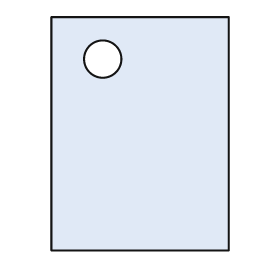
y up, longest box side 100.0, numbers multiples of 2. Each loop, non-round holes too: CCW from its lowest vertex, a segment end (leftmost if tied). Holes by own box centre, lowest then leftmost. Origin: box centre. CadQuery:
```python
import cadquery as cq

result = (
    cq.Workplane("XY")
    .moveTo(-38.0, -50.0)
    .lineTo(38.0, -50.0)
    .lineTo(38.0, 50.0)
    .lineTo(-38.0, 50.0)
    .close()
    .moveTo(-16.0, 32.0)
    .circle(8.0)
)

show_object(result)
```